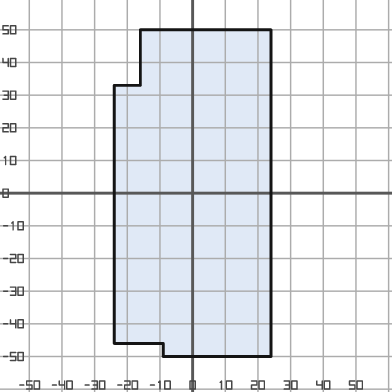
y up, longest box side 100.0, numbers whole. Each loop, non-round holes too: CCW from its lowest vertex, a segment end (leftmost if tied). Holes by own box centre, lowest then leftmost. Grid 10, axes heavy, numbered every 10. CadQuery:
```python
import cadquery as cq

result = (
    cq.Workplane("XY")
    .moveTo(-9.0, -50.0)
    .lineTo(24.0, -50.0)
    .lineTo(24.0, 50.0)
    .lineTo(-16.0, 50.0)
    .lineTo(-16.0, 33.0)
    .lineTo(-24.0, 33.0)
    .lineTo(-24.0, -46.0)
    .lineTo(-9.0, -46.0)
    .close()
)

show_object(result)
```